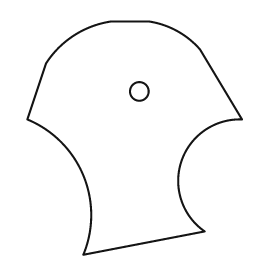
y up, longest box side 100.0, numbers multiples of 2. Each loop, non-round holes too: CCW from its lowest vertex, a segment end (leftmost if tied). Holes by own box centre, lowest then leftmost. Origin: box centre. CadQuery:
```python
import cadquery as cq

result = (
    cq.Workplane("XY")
    .moveTo(-22.0, -50.0)
    .lineTo(30.0, -40.0)
    .threePointArc((20.0, -10.0), (46.0, 8.0))
    .lineTo(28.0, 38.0)
    .threePointArc((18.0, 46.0), (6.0, 50.0))
    .lineTo(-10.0, 50.0)
    .threePointArc((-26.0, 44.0), (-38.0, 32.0))
    .lineTo(-46.0, 8.0)
    .threePointArc((-22.0, -16.0), (-22.0, -50.0))
    .close()
    .moveTo(2.0, 20.0)
    .circle(4.0)
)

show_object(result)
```